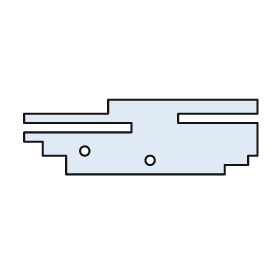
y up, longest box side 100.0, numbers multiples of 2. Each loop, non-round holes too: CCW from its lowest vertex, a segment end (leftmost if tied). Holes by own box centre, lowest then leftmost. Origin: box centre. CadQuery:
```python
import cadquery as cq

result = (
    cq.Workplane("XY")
    .moveTo(-32.0, -16.0)
    .lineTo(36.0, -16.0)
    .lineTo(36.0, -12.0)
    .lineTo(46.0, -12.0)
    .lineTo(46.0, -8.0)
    .lineTo(50.0, -8.0)
    .lineTo(50.0, 6.0)
    .lineTo(16.0, 6.0)
    .lineTo(16.0, 10.0)
    .lineTo(50.0, 10.0)
    .lineTo(50.0, 16.0)
    .lineTo(-14.0, 16.0)
    .lineTo(-14.0, 10.0)
    .lineTo(-50.0, 10.0)
    .lineTo(-50.0, 6.0)
    .lineTo(-4.0, 6.0)
    .lineTo(-4.0, 2.0)
    .lineTo(-50.0, 2.0)
    .lineTo(-50.0, -2.0)
    .lineTo(-42.0, -2.0)
    .lineTo(-42.0, -8.0)
    .lineTo(-32.0, -8.0)
    .close()
    .moveTo(4.0, -10.0)
    .circle(2.0)
    .moveTo(-24.0, -6.0)
    .circle(2.0)
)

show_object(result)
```